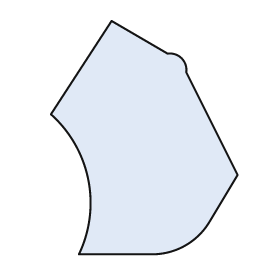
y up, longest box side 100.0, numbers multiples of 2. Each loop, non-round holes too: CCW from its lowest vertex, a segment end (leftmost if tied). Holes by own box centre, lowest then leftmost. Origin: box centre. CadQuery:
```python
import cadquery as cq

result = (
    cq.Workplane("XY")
    .moveTo(-28.0, -50.0)
    .lineTo(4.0, -50.0)
    .threePointArc((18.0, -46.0), (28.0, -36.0))
    .lineTo(40.0, -16.0)
    .lineTo(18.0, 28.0)
    .threePointArc((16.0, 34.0), (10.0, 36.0))
    .lineTo(-14.0, 50.0)
    .lineTo(-40.0, 10.0)
    .threePointArc((-24.0, -18.0), (-28.0, -50.0))
    .close()
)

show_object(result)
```